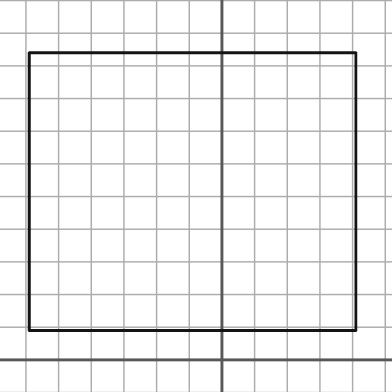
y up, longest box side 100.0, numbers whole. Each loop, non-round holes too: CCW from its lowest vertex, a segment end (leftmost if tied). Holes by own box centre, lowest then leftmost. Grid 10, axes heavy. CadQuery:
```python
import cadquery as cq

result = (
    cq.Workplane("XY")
    .moveTo(-59.0, 9.0)
    .lineTo(41.0, 9.0)
    .lineTo(41.0, 94.0)
    .lineTo(-59.0, 94.0)
    .close()
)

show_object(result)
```